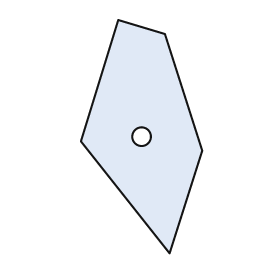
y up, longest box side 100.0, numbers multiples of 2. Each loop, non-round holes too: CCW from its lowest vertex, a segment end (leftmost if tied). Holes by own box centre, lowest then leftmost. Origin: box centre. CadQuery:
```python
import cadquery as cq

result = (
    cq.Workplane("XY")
    .moveTo(12.0, -50.0)
    .lineTo(26.0, -6.0)
    .lineTo(10.0, 44.0)
    .lineTo(-10.0, 50.0)
    .lineTo(-26.0, -2.0)
    .close()
    .moveTo(0.0, 0.0)
    .circle(4.0)
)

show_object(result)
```